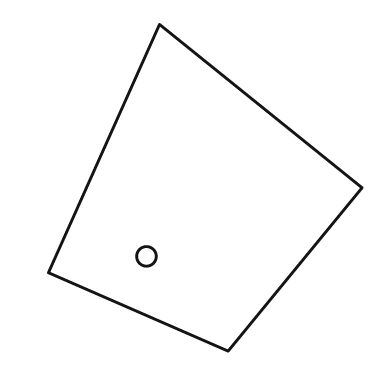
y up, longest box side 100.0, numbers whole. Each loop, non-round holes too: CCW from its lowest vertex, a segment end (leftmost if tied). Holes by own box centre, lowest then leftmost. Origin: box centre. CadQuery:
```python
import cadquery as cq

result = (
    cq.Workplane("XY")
    .moveTo(7.0, -50.0)
    .lineTo(48.0, 0.0)
    .lineTo(-14.0, 50.0)
    .lineTo(-48.0, -26.0)
    .close()
    .moveTo(-18.0, -21.0)
    .circle(3.0)
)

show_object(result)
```